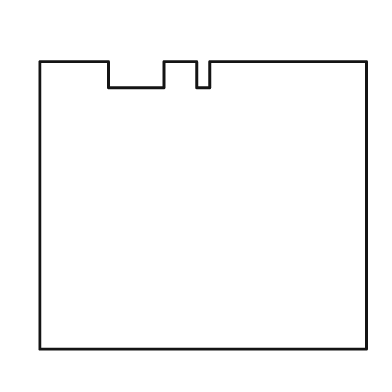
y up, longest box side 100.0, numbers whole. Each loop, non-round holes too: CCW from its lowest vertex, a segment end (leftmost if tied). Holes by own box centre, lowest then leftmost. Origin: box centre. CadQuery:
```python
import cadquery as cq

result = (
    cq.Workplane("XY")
    .moveTo(-50.0, -44.0)
    .lineTo(50.0, -44.0)
    .lineTo(50.0, 44.0)
    .lineTo(2.0, 44.0)
    .lineTo(2.0, 36.0)
    .lineTo(-2.0, 36.0)
    .lineTo(-2.0, 44.0)
    .lineTo(-12.0, 44.0)
    .lineTo(-12.0, 36.0)
    .lineTo(-29.0, 36.0)
    .lineTo(-29.0, 44.0)
    .lineTo(-50.0, 44.0)
    .close()
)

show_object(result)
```